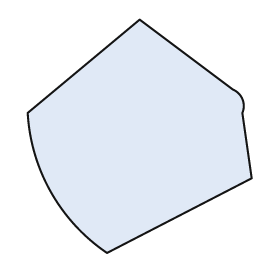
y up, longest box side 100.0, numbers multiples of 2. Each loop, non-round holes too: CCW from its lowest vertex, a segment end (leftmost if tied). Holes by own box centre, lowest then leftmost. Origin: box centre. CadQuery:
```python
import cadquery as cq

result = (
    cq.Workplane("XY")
    .moveTo(-14.0, -50.0)
    .lineTo(48.0, -18.0)
    .lineTo(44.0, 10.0)
    .threePointArc((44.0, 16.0), (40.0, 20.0))
    .lineTo(0.0, 50.0)
    .lineTo(-48.0, 10.0)
    .threePointArc((-38.0, -24.0), (-14.0, -50.0))
    .close()
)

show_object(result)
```